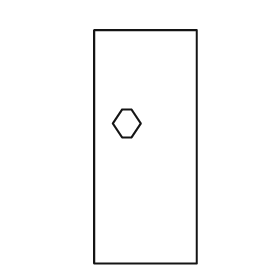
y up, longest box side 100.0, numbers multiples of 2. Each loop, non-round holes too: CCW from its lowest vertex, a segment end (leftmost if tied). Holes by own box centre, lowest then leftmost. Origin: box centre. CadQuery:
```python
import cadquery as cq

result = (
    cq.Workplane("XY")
    .moveTo(-22.0, -50.0)
    .lineTo(22.0, -50.0)
    .lineTo(22.0, 50.0)
    .lineTo(-22.0, 50.0)
    .close()
    .moveTo(-10.0, 4.0)
    .lineTo(-6.0, 4.0)
    .lineTo(-2.0, 10.0)
    .lineTo(-6.0, 16.0)
    .lineTo(-10.0, 16.0)
    .lineTo(-14.0, 10.0)
    .close()
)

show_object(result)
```